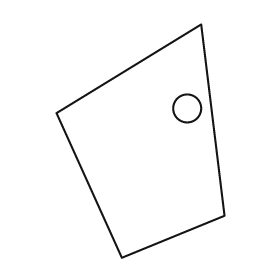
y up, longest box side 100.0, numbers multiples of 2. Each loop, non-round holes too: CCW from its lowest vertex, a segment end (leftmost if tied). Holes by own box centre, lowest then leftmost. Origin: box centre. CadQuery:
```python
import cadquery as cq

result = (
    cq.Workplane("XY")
    .moveTo(-8.0, -50.0)
    .lineTo(36.0, -32.0)
    .lineTo(26.0, 50.0)
    .lineTo(-36.0, 12.0)
    .close()
    .moveTo(20.0, 14.0)
    .circle(6.0)
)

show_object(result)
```